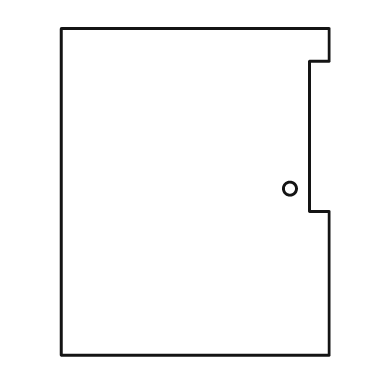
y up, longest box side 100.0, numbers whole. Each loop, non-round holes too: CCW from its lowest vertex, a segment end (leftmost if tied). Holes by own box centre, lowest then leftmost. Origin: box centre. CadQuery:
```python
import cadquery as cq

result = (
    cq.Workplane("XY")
    .moveTo(-41.0, -50.0)
    .lineTo(41.0, -50.0)
    .lineTo(41.0, -6.0)
    .lineTo(35.0, -6.0)
    .lineTo(35.0, 40.0)
    .lineTo(41.0, 40.0)
    .lineTo(41.0, 50.0)
    .lineTo(-41.0, 50.0)
    .close()
    .moveTo(29.0, 1.0)
    .circle(2.0)
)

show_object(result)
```